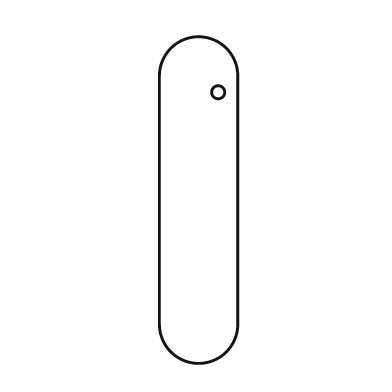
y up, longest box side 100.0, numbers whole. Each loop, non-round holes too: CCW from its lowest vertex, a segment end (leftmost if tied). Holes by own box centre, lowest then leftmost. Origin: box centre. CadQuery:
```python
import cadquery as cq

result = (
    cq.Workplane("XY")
    .moveTo(-12.0, -38.0)
    .threePointArc((0.0, -50.0), (12.0, -38.0))
    .lineTo(12.0, 38.0)
    .threePointArc((0.0, 50.0), (-12.0, 38.0))
    .close()
    .moveTo(6.0, 33.0)
    .circle(2.0)
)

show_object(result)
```